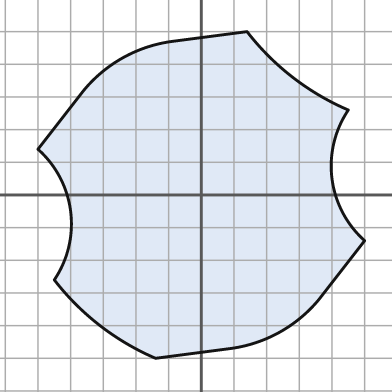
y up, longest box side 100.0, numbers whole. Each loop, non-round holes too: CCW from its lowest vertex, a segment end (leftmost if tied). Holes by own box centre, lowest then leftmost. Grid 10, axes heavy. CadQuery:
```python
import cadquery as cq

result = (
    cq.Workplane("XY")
    .moveTo(-14.0, -50.0)
    .lineTo(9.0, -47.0)
    .threePointArc((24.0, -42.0), (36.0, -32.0))
    .lineTo(50.0, -14.0)
    .threePointArc((40.0, 5.0), (45.0, 26.0))
    .threePointArc((28.0, 36.0), (14.0, 50.0))
    .lineTo(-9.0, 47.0)
    .threePointArc((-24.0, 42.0), (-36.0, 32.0))
    .lineTo(-50.0, 14.0)
    .threePointArc((-40.0, -5.0), (-45.0, -26.0))
    .threePointArc((-31.0, -40.0), (-14.0, -50.0))
    .close()
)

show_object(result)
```